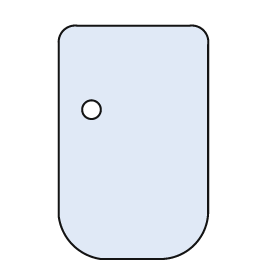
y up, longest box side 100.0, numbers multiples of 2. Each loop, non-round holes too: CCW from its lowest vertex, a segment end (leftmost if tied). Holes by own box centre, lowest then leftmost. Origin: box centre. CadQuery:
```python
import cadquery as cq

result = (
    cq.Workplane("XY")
    .moveTo(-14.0, -50.0)
    .lineTo(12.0, -50.0)
    .threePointArc((26.0, -44.0), (32.0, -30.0))
    .lineTo(32.0, 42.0)
    .threePointArc((30.0, 48.0), (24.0, 50.0))
    .lineTo(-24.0, 50.0)
    .threePointArc((-30.0, 48.0), (-32.0, 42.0))
    .lineTo(-32.0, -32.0)
    .threePointArc((-26.0, -44.0), (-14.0, -50.0))
    .close()
    .moveTo(-18.0, 14.0)
    .circle(4.0)
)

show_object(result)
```